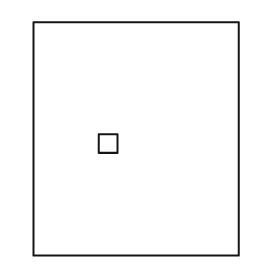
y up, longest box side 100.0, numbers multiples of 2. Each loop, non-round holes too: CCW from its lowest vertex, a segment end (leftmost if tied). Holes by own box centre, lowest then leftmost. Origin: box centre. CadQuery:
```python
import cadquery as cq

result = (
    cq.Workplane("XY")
    .moveTo(-44.0, -50.0)
    .lineTo(44.0, -50.0)
    .lineTo(44.0, 50.0)
    .lineTo(-44.0, 50.0)
    .close()
    .moveTo(-16.0, -6.0)
    .lineTo(-8.0, -6.0)
    .lineTo(-8.0, 2.0)
    .lineTo(-16.0, 2.0)
    .close()
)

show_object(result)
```